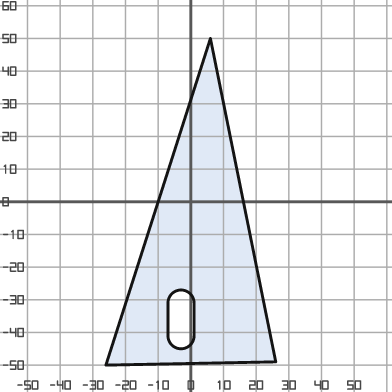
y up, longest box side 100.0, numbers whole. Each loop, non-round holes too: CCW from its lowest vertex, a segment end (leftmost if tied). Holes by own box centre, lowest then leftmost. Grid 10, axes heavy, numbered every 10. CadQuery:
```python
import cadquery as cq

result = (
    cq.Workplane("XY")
    .moveTo(-26.0, -50.0)
    .lineTo(26.0, -49.0)
    .lineTo(6.0, 50.0)
    .close()
    .moveTo(-7.0, -41.0)
    .threePointArc((-3.0, -45.0), (1.0, -41.0))
    .lineTo(1.0, -31.0)
    .threePointArc((-3.0, -27.0), (-7.0, -31.0))
    .close()
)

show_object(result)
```